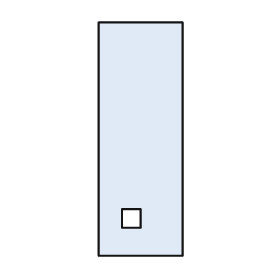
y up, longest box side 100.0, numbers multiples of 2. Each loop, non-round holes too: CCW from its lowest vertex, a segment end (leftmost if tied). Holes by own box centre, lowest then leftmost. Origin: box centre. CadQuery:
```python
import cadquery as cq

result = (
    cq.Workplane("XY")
    .moveTo(-18.0, -50.0)
    .lineTo(18.0, -50.0)
    .lineTo(18.0, 50.0)
    .lineTo(-18.0, 50.0)
    .close()
    .moveTo(-8.0, -38.0)
    .lineTo(0.0, -38.0)
    .lineTo(0.0, -30.0)
    .lineTo(-8.0, -30.0)
    .close()
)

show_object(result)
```